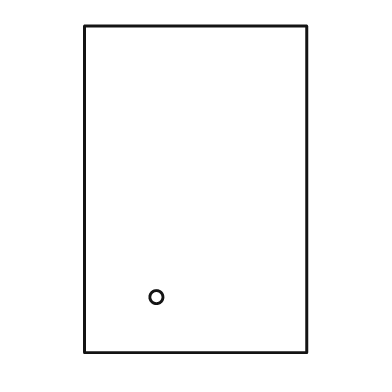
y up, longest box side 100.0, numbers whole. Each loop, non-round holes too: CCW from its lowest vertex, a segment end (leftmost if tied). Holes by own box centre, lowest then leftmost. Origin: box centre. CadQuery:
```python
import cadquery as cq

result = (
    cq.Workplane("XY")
    .moveTo(-34.0, -50.0)
    .lineTo(34.0, -50.0)
    .lineTo(34.0, 50.0)
    .lineTo(-34.0, 50.0)
    .close()
    .moveTo(-12.0, -33.0)
    .circle(2.0)
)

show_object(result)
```